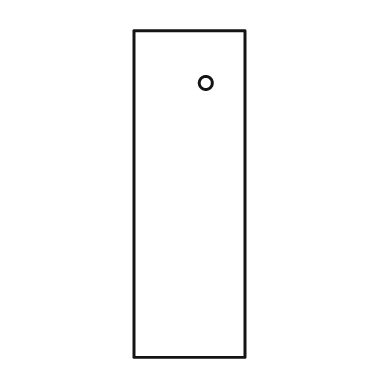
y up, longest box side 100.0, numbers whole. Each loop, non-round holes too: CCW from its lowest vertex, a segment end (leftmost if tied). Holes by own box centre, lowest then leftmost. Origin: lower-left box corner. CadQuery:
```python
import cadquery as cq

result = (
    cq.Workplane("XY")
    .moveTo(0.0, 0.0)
    .lineTo(34.0, 0.0)
    .lineTo(34.0, 100.0)
    .lineTo(0.0, 100.0)
    .close()
    .moveTo(22.0, 84.0)
    .circle(2.0)
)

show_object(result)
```